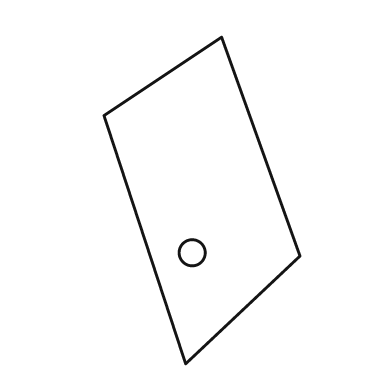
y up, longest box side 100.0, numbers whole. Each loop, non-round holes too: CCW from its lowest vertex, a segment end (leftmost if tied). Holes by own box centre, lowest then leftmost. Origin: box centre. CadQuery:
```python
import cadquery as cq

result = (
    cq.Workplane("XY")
    .moveTo(-5.0, -50.0)
    .lineTo(30.0, -17.0)
    .lineTo(6.0, 50.0)
    .lineTo(-30.0, 26.0)
    .close()
    .moveTo(-3.0, -16.0)
    .circle(4.0)
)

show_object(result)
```